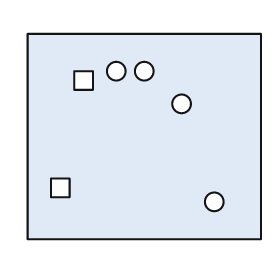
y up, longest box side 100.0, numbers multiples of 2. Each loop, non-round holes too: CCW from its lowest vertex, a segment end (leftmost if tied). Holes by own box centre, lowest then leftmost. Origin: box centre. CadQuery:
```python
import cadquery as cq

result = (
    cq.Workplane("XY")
    .moveTo(-50.0, -44.0)
    .lineTo(50.0, -44.0)
    .lineTo(50.0, 44.0)
    .lineTo(-50.0, 44.0)
    .close()
    .moveTo(30.0, -28.0)
    .circle(4.0)
    .moveTo(-40.0, -26.0)
    .lineTo(-32.0, -26.0)
    .lineTo(-32.0, -18.0)
    .lineTo(-40.0, -18.0)
    .close()
    .moveTo(16.0, 14.0)
    .circle(4.0)
    .moveTo(-30.0, 20.0)
    .lineTo(-22.0, 20.0)
    .lineTo(-22.0, 28.0)
    .lineTo(-30.0, 28.0)
    .close()
    .moveTo(-12.0, 28.0)
    .circle(4.0)
    .moveTo(0.0, 28.0)
    .circle(4.0)
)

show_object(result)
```